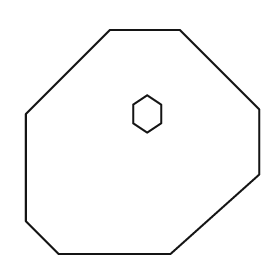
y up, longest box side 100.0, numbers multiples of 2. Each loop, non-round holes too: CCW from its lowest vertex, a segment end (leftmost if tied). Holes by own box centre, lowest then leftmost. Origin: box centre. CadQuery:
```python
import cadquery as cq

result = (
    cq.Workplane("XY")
    .moveTo(-36.0, -48.0)
    .lineTo(12.0, -48.0)
    .lineTo(50.0, -14.0)
    .lineTo(50.0, 14.0)
    .lineTo(16.0, 48.0)
    .lineTo(-14.0, 48.0)
    .lineTo(-50.0, 12.0)
    .lineTo(-50.0, -34.0)
    .close()
    .moveTo(2.0, 4.0)
    .lineTo(8.0, 8.0)
    .lineTo(8.0, 16.0)
    .lineTo(2.0, 20.0)
    .lineTo(-4.0, 16.0)
    .lineTo(-4.0, 8.0)
    .close()
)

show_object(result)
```